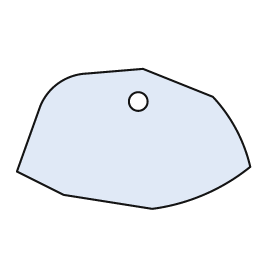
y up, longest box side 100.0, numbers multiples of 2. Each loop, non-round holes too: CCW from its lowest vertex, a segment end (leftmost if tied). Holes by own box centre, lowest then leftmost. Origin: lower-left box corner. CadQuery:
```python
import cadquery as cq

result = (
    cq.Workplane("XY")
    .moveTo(58.0, 0.0)
    .threePointArc((80.0, 6.0), (100.0, 18.0))
    .threePointArc((94.0, 34.0), (84.0, 48.0))
    .lineTo(54.0, 60.0)
    .lineTo(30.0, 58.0)
    .threePointArc((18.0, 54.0), (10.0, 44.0))
    .lineTo(0.0, 16.0)
    .lineTo(20.0, 6.0)
    .close()
    .moveTo(52.0, 46.0)
    .circle(4.0)
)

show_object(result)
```